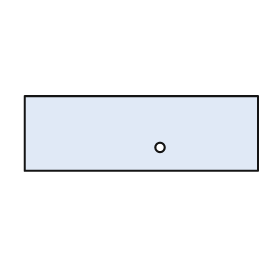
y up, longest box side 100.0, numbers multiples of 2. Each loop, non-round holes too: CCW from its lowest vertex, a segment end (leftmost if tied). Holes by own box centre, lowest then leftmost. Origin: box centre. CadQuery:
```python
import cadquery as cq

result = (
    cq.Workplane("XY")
    .moveTo(-50.0, -16.0)
    .lineTo(50.0, -16.0)
    .lineTo(50.0, 16.0)
    .lineTo(-50.0, 16.0)
    .close()
    .moveTo(8.0, -6.0)
    .circle(2.0)
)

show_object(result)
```